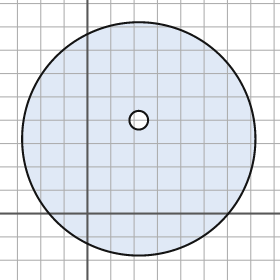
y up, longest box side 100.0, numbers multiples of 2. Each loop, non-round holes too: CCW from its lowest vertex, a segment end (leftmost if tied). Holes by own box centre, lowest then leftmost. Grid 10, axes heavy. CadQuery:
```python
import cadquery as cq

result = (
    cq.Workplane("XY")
    .moveTo(22.0, 32.0)
    .circle(50.0)
    .moveTo(22.0, 40.0)
    .circle(4.0)
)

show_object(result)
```